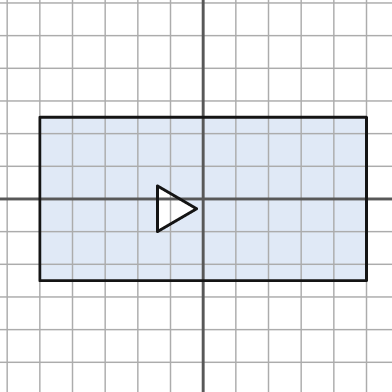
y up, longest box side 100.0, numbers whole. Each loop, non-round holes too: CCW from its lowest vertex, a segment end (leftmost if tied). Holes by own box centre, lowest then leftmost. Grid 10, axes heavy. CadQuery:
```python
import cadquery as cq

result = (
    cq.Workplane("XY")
    .moveTo(-50.0, -25.0)
    .lineTo(50.0, -25.0)
    .lineTo(50.0, 25.0)
    .lineTo(-50.0, 25.0)
    .close()
    .moveTo(-14.0, -10.0)
    .lineTo(-2.0, -3.0)
    .lineTo(-14.0, 4.0)
    .close()
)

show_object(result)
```